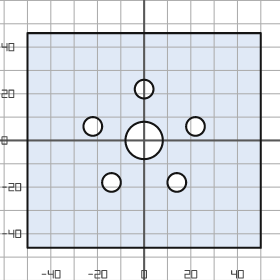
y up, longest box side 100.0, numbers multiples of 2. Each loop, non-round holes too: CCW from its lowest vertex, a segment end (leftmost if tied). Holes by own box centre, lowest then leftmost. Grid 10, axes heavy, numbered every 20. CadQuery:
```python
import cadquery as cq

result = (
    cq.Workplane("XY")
    .moveTo(-50.0, -46.0)
    .lineTo(50.0, -46.0)
    .lineTo(50.0, 46.0)
    .lineTo(-50.0, 46.0)
    .close()
    .moveTo(-14.0, -18.0)
    .circle(4.0)
    .moveTo(14.0, -18.0)
    .circle(4.0)
    .moveTo(0.0, 0.0)
    .circle(8.0)
    .moveTo(-22.0, 6.0)
    .circle(4.0)
    .moveTo(22.0, 6.0)
    .circle(4.0)
    .moveTo(0.0, 22.0)
    .circle(4.0)
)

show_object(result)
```